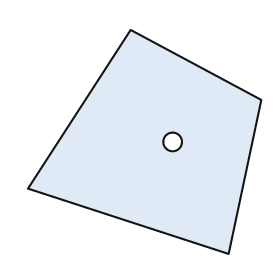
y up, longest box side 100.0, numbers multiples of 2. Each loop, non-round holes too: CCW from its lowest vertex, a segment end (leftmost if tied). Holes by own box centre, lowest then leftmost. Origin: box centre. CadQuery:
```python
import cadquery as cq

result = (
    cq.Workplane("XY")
    .moveTo(36.0, -48.0)
    .lineTo(50.0, 18.0)
    .lineTo(-6.0, 48.0)
    .lineTo(-50.0, -20.0)
    .close()
    .moveTo(12.0, 0.0)
    .circle(4.0)
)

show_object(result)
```